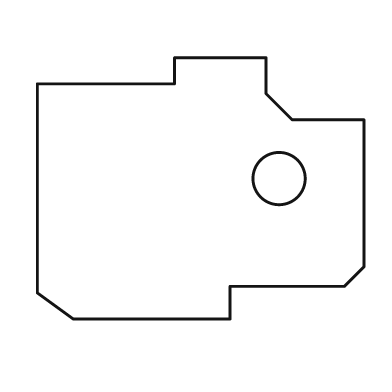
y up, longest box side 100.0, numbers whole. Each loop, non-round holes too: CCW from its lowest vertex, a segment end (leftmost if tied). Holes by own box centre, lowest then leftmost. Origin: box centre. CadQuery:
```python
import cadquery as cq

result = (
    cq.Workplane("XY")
    .moveTo(-39.0, -40.0)
    .lineTo(9.0, -40.0)
    .lineTo(9.0, -30.0)
    .lineTo(44.0, -30.0)
    .lineTo(50.0, -24.0)
    .lineTo(50.0, 21.0)
    .lineTo(28.0, 21.0)
    .lineTo(20.0, 29.0)
    .lineTo(20.0, 40.0)
    .lineTo(-8.0, 40.0)
    .lineTo(-8.0, 32.0)
    .lineTo(-50.0, 32.0)
    .lineTo(-50.0, -32.0)
    .close()
    .moveTo(24.0, 3.0)
    .circle(8.0)
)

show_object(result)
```